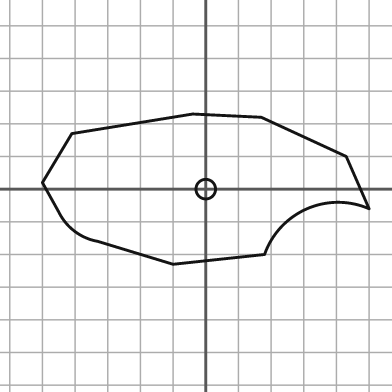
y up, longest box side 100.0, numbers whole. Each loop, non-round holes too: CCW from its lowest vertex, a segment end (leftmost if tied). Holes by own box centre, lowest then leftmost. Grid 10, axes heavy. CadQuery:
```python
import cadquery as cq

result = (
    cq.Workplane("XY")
    .moveTo(-10.0, -23.0)
    .lineTo(18.0, -20.0)
    .threePointArc((31.0, -6.0), (50.0, -6.0))
    .lineTo(43.0, 10.0)
    .lineTo(17.0, 22.0)
    .lineTo(-4.0, 23.0)
    .lineTo(-41.0, 17.0)
    .lineTo(-50.0, 2.0)
    .lineTo(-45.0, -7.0)
    .threePointArc((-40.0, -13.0), (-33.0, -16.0))
    .close()
    .moveTo(0.0, 0.0)
    .circle(3.0)
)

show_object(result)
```